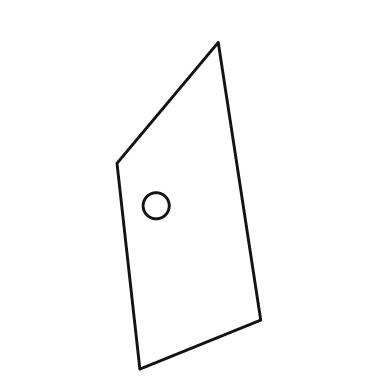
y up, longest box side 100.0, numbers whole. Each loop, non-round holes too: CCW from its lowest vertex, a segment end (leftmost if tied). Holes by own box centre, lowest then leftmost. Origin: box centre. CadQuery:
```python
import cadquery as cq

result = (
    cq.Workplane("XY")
    .moveTo(-15.0, -50.0)
    .lineTo(22.0, -35.0)
    .lineTo(9.0, 50.0)
    .lineTo(-22.0, 13.0)
    .close()
    .moveTo(-10.0, 0.0)
    .circle(4.0)
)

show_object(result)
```